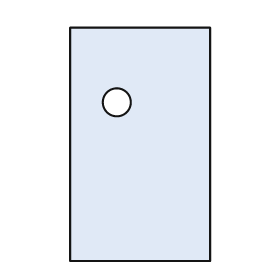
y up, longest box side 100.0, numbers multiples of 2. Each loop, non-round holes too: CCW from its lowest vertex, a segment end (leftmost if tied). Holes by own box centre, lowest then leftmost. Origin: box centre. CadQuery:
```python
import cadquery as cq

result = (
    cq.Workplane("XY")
    .moveTo(-30.0, -50.0)
    .lineTo(30.0, -50.0)
    .lineTo(30.0, 50.0)
    .lineTo(-30.0, 50.0)
    .close()
    .moveTo(-10.0, 18.0)
    .circle(6.0)
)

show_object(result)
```